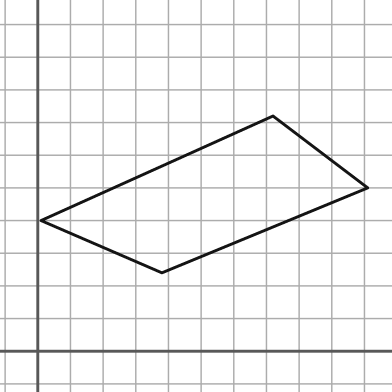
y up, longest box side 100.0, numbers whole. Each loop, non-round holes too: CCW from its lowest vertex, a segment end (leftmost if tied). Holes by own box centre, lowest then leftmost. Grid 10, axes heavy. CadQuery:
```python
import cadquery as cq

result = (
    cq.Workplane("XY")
    .moveTo(38.0, 24.0)
    .lineTo(101.0, 50.0)
    .lineTo(72.0, 72.0)
    .lineTo(1.0, 40.0)
    .close()
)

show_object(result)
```